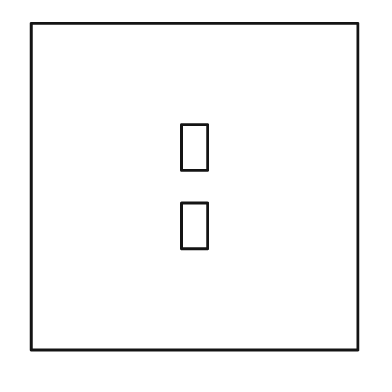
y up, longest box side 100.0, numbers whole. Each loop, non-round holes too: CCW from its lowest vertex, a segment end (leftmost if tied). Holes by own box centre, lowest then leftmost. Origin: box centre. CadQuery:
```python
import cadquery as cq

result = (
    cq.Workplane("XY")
    .moveTo(-50.0, -50.0)
    .lineTo(50.0, -50.0)
    .lineTo(50.0, 50.0)
    .lineTo(-50.0, 50.0)
    .close()
    .moveTo(-4.0, -19.0)
    .lineTo(4.0, -19.0)
    .lineTo(4.0, -5.0)
    .lineTo(-4.0, -5.0)
    .close()
    .moveTo(-4.0, 5.0)
    .lineTo(4.0, 5.0)
    .lineTo(4.0, 19.0)
    .lineTo(-4.0, 19.0)
    .close()
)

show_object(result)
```